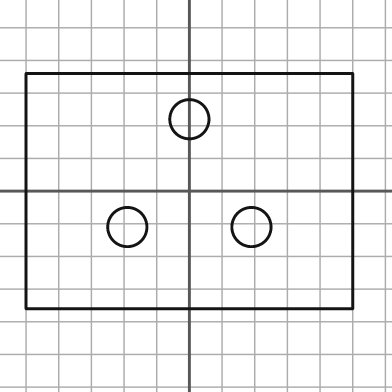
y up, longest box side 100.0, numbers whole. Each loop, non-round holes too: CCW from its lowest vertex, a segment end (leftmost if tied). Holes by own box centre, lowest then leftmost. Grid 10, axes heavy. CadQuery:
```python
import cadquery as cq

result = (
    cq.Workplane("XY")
    .moveTo(-50.0, -36.0)
    .lineTo(50.0, -36.0)
    .lineTo(50.0, 36.0)
    .lineTo(-50.0, 36.0)
    .close()
    .moveTo(-19.0, -11.0)
    .circle(6.0)
    .moveTo(19.0, -11.0)
    .circle(6.0)
    .moveTo(0.0, 22.0)
    .circle(6.0)
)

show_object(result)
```